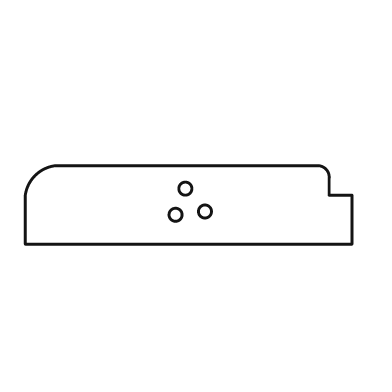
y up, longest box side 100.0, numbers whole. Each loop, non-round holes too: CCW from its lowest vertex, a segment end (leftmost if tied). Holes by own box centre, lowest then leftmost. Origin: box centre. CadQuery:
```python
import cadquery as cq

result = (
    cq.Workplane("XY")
    .moveTo(-50.0, -12.0)
    .lineTo(50.0, -12.0)
    .lineTo(50.0, 3.0)
    .lineTo(43.0, 3.0)
    .lineTo(43.0, 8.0)
    .threePointArc((42.0, 11.0), (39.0, 12.0))
    .lineTo(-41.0, 12.0)
    .threePointArc((-47.0, 9.0), (-50.0, 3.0))
    .close()
    .moveTo(-4.0, -3.0)
    .circle(2.0)
    .moveTo(5.0, -2.0)
    .circle(2.0)
    .moveTo(-1.0, 5.0)
    .circle(2.0)
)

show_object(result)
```